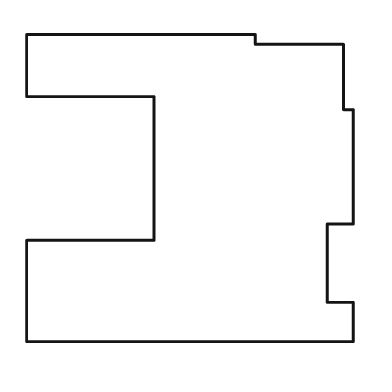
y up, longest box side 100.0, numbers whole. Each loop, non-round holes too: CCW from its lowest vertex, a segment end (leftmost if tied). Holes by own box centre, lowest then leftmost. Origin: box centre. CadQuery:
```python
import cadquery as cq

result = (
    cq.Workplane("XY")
    .moveTo(-50.0, -47.0)
    .lineTo(50.0, -47.0)
    .lineTo(50.0, -35.0)
    .lineTo(42.0, -35.0)
    .lineTo(42.0, -11.0)
    .lineTo(50.0, -11.0)
    .lineTo(50.0, 24.0)
    .lineTo(47.0, 24.0)
    .lineTo(47.0, 44.0)
    .lineTo(20.0, 44.0)
    .lineTo(20.0, 47.0)
    .lineTo(-50.0, 47.0)
    .lineTo(-50.0, 28.0)
    .lineTo(-11.0, 28.0)
    .lineTo(-11.0, -16.0)
    .lineTo(-50.0, -16.0)
    .close()
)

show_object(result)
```